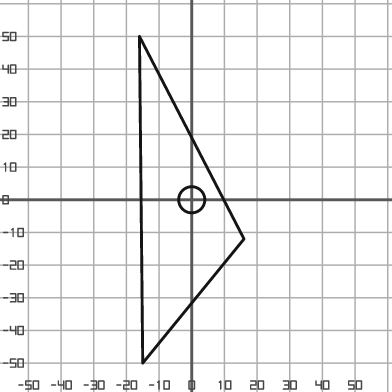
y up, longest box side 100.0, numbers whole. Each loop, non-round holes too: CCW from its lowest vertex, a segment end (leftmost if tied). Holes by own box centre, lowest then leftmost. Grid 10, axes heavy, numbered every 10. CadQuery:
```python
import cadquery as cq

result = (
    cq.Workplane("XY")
    .moveTo(-15.0, -50.0)
    .lineTo(16.0, -12.0)
    .lineTo(-16.0, 50.0)
    .close()
    .moveTo(0.0, 0.0)
    .circle(4.0)
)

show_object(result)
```